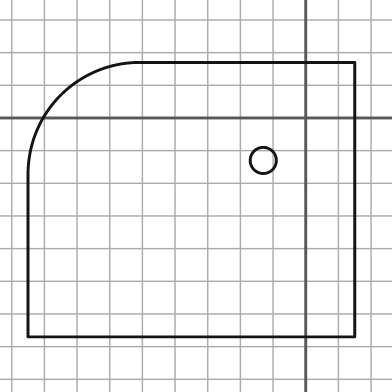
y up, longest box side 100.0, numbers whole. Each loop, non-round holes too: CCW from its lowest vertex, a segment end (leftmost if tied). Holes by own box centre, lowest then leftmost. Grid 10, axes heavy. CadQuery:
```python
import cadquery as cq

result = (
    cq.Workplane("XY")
    .moveTo(-85.0, -67.0)
    .lineTo(15.0, -67.0)
    .lineTo(15.0, 17.0)
    .lineTo(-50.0, 17.0)
    .threePointArc((-75.0, 7.0), (-85.0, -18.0))
    .close()
    .moveTo(-13.0, -13.0)
    .circle(4.0)
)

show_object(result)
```